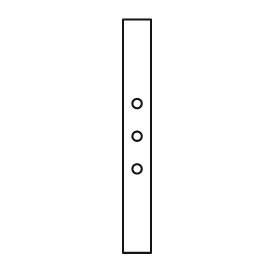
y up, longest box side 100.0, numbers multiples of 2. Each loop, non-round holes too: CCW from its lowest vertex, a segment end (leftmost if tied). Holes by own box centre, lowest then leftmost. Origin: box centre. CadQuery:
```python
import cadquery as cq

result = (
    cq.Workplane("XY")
    .moveTo(-6.0, -50.0)
    .lineTo(6.0, -50.0)
    .lineTo(6.0, 50.0)
    .lineTo(-6.0, 50.0)
    .close()
    .moveTo(0.0, -14.0)
    .circle(2.0)
    .moveTo(0.0, 0.0)
    .circle(2.0)
    .moveTo(0.0, 14.0)
    .circle(2.0)
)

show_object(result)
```